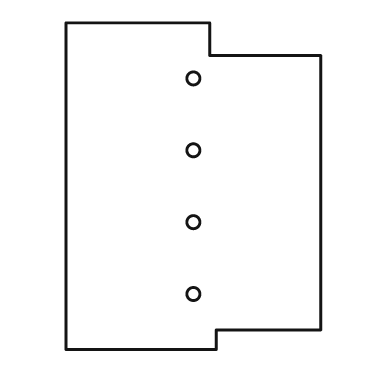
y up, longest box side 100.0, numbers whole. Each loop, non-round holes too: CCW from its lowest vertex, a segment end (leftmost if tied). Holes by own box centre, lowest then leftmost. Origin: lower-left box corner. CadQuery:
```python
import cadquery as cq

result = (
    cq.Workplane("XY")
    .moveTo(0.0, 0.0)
    .lineTo(46.0, 0.0)
    .lineTo(46.0, 6.0)
    .lineTo(78.0, 6.0)
    .lineTo(78.0, 90.0)
    .lineTo(44.0, 90.0)
    .lineTo(44.0, 100.0)
    .lineTo(0.0, 100.0)
    .close()
    .moveTo(39.0, 17.0)
    .circle(2.0)
    .moveTo(39.0, 39.0)
    .circle(2.0)
    .moveTo(39.0, 61.0)
    .circle(2.0)
    .moveTo(39.0, 83.0)
    .circle(2.0)
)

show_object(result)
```